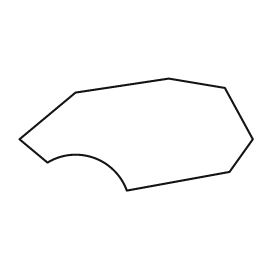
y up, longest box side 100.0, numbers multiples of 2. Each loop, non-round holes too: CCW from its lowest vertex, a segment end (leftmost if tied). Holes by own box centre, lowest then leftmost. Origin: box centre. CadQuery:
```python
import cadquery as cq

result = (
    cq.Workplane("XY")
    .moveTo(-4.0, -24.0)
    .lineTo(40.0, -16.0)
    .lineTo(50.0, -2.0)
    .lineTo(38.0, 20.0)
    .lineTo(14.0, 24.0)
    .lineTo(-26.0, 18.0)
    .lineTo(-50.0, -2.0)
    .lineTo(-38.0, -12.0)
    .threePointArc((-18.0, -10.0), (-4.0, -24.0))
    .close()
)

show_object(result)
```